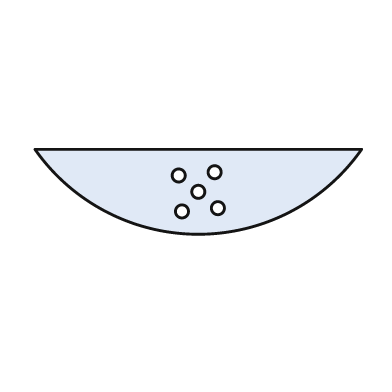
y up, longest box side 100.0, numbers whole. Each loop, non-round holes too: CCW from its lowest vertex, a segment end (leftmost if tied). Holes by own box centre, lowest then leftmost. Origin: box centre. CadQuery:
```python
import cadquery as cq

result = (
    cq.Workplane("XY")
    .moveTo(-50.0, 13.0)
    .threePointArc((0.0, -13.0), (50.0, 13.0))
    .close()
    .moveTo(-5.0, -6.0)
    .circle(2.0)
    .moveTo(6.0, -5.0)
    .circle(2.0)
    .moveTo(0.0, 0.0)
    .circle(2.0)
    .moveTo(-6.0, 5.0)
    .circle(2.0)
    .moveTo(5.0, 6.0)
    .circle(2.0)
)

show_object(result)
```